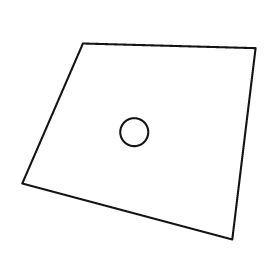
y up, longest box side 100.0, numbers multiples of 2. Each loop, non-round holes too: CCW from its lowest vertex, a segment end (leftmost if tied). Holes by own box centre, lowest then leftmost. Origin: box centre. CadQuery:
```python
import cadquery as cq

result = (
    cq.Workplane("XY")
    .moveTo(40.0, -42.0)
    .lineTo(50.0, 40.0)
    .lineTo(-24.0, 42.0)
    .lineTo(-50.0, -18.0)
    .close()
    .moveTo(-2.0, 4.0)
    .circle(6.0)
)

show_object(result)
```